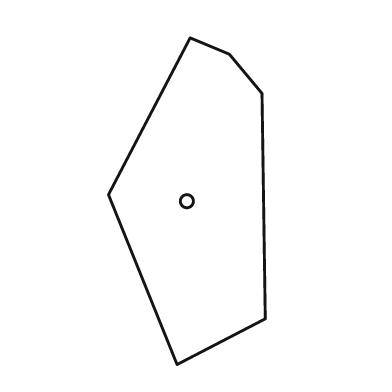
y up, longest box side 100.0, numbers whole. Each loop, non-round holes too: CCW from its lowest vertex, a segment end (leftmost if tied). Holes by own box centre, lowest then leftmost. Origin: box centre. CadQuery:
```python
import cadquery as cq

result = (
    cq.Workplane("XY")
    .moveTo(-3.0, -50.0)
    .lineTo(24.0, -36.0)
    .lineTo(23.0, 33.0)
    .lineTo(13.0, 45.0)
    .lineTo(1.0, 50.0)
    .lineTo(-24.0, 2.0)
    .close()
    .moveTo(0.0, 0.0)
    .circle(2.0)
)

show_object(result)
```